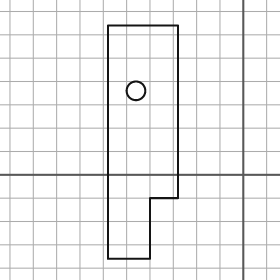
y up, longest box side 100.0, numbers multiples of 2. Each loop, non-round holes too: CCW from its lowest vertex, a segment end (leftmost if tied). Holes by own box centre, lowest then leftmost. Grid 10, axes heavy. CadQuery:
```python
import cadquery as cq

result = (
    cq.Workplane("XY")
    .moveTo(-58.0, -36.0)
    .lineTo(-40.0, -36.0)
    .lineTo(-40.0, -10.0)
    .lineTo(-28.0, -10.0)
    .lineTo(-28.0, 64.0)
    .lineTo(-58.0, 64.0)
    .close()
    .moveTo(-46.0, 36.0)
    .circle(4.0)
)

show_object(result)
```